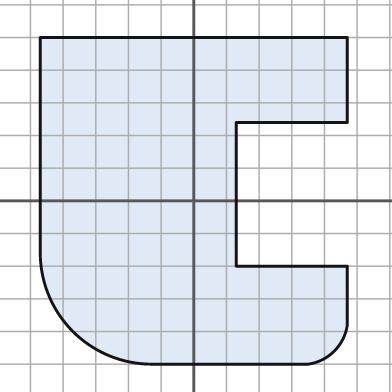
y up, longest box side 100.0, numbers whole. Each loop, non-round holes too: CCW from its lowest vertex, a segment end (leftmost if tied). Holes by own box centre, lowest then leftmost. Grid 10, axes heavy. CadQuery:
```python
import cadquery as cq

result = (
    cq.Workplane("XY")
    .moveTo(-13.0, -50.0)
    .lineTo(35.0, -50.0)
    .threePointArc((43.0, -46.0), (47.0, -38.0))
    .lineTo(47.0, -20.0)
    .lineTo(13.0, -20.0)
    .lineTo(13.0, 24.0)
    .lineTo(47.0, 24.0)
    .lineTo(47.0, 50.0)
    .lineTo(-47.0, 50.0)
    .lineTo(-47.0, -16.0)
    .threePointArc((-37.0, -40.0), (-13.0, -50.0))
    .close()
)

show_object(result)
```